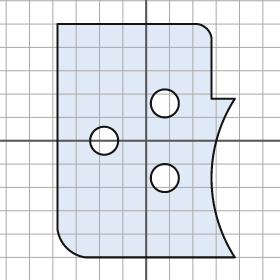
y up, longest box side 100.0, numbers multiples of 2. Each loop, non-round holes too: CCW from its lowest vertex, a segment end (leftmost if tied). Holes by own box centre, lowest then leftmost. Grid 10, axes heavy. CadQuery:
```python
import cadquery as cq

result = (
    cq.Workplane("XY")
    .moveTo(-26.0, -50.0)
    .lineTo(38.0, -50.0)
    .threePointArc((28.0, -16.0), (38.0, 18.0))
    .lineTo(28.0, 18.0)
    .lineTo(28.0, 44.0)
    .threePointArc((26.0, 48.0), (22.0, 50.0))
    .lineTo(-38.0, 50.0)
    .lineTo(-38.0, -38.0)
    .threePointArc((-34.0, -46.0), (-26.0, -50.0))
    .close()
    .moveTo(8.0, -16.0)
    .circle(6.0)
    .moveTo(-18.0, 0.0)
    .circle(6.0)
    .moveTo(8.0, 16.0)
    .circle(6.0)
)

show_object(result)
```